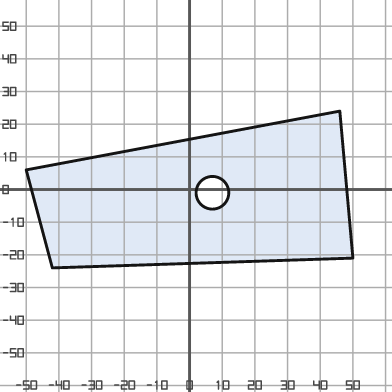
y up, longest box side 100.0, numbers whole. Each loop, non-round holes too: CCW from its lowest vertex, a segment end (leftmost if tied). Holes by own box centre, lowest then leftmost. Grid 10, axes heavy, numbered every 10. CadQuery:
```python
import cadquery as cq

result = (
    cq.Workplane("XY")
    .moveTo(-42.0, -24.0)
    .lineTo(50.0, -21.0)
    .lineTo(46.0, 24.0)
    .lineTo(-50.0, 6.0)
    .close()
    .moveTo(7.0, -1.0)
    .circle(5.0)
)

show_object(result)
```